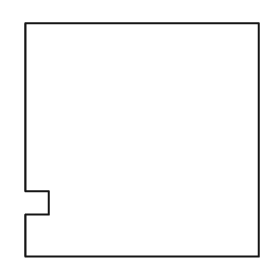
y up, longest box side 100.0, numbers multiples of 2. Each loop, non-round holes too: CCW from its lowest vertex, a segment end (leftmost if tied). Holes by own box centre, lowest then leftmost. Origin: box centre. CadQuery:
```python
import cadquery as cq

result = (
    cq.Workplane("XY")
    .moveTo(-50.0, -50.0)
    .lineTo(50.0, -50.0)
    .lineTo(50.0, 50.0)
    .lineTo(-50.0, 50.0)
    .lineTo(-50.0, -22.0)
    .lineTo(-40.0, -22.0)
    .lineTo(-40.0, -32.0)
    .lineTo(-50.0, -32.0)
    .close()
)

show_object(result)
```